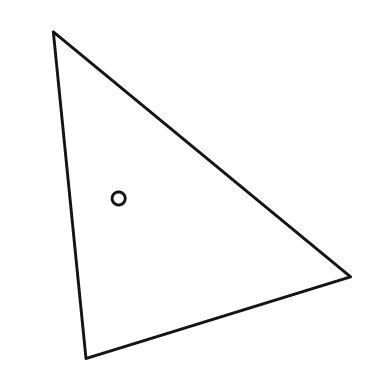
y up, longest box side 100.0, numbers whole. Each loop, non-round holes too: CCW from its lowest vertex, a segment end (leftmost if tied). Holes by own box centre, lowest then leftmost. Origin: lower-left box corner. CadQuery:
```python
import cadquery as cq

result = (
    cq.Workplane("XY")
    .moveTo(10.0, 0.0)
    .lineTo(91.0, 25.0)
    .lineTo(0.0, 100.0)
    .close()
    .moveTo(20.0, 49.0)
    .circle(2.0)
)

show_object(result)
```